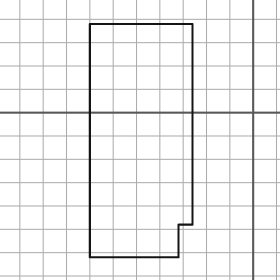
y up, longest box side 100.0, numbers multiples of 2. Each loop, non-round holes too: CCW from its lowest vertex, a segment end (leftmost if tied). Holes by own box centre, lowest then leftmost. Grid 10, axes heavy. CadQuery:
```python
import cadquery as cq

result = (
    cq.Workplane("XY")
    .moveTo(-70.0, -62.0)
    .lineTo(-32.0, -62.0)
    .lineTo(-32.0, -48.0)
    .lineTo(-26.0, -48.0)
    .lineTo(-26.0, 38.0)
    .lineTo(-70.0, 38.0)
    .close()
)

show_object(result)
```